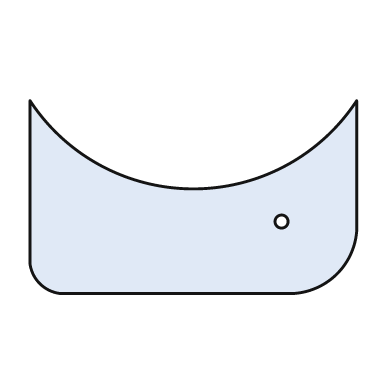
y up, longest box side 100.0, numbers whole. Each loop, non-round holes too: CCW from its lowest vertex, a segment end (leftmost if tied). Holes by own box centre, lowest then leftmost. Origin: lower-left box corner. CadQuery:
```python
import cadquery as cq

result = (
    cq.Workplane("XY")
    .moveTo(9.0, 0.0)
    .lineTo(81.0, 0.0)
    .threePointArc((94.0, 6.0), (100.0, 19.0))
    .lineTo(100.0, 59.0)
    .threePointArc((50.0, 32.0), (0.0, 59.0))
    .lineTo(0.0, 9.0)
    .threePointArc((3.0, 3.0), (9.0, 0.0))
    .close()
    .moveTo(77.0, 22.0)
    .circle(2.0)
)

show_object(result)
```